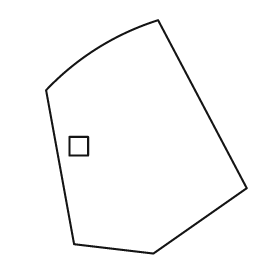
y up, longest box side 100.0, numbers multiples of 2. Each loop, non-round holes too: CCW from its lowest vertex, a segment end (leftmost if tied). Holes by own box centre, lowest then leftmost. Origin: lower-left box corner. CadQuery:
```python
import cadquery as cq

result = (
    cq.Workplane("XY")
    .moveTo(46.0, 0.0)
    .lineTo(86.0, 28.0)
    .lineTo(48.0, 100.0)
    .threePointArc((22.0, 88.0), (0.0, 70.0))
    .lineTo(12.0, 4.0)
    .close()
    .moveTo(10.0, 42.0)
    .lineTo(18.0, 42.0)
    .lineTo(18.0, 50.0)
    .lineTo(10.0, 50.0)
    .close()
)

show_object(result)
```